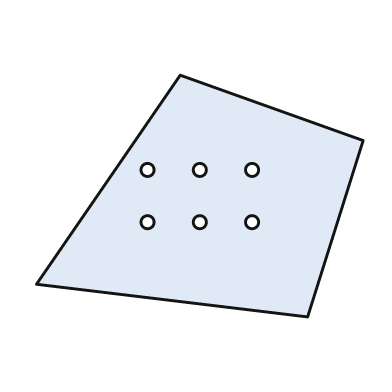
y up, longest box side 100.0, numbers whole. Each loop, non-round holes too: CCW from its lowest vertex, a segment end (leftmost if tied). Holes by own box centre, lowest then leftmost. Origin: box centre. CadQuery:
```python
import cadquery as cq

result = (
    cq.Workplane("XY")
    .moveTo(33.0, -37.0)
    .lineTo(50.0, 17.0)
    .lineTo(-6.0, 37.0)
    .lineTo(-50.0, -27.0)
    .close()
    .moveTo(-16.0, -8.0)
    .circle(2.0)
    .moveTo(0.0, -8.0)
    .circle(2.0)
    .moveTo(16.0, -8.0)
    .circle(2.0)
    .moveTo(-16.0, 8.0)
    .circle(2.0)
    .moveTo(0.0, 8.0)
    .circle(2.0)
    .moveTo(16.0, 8.0)
    .circle(2.0)
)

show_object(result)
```